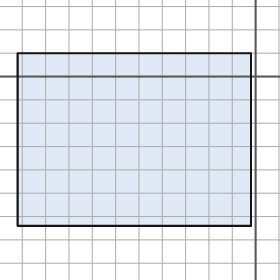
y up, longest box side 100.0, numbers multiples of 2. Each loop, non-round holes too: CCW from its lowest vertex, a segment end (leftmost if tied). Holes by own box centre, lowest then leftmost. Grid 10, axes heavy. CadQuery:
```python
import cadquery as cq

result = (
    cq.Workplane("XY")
    .moveTo(-102.0, -64.0)
    .lineTo(-2.0, -64.0)
    .lineTo(-2.0, 10.0)
    .lineTo(-102.0, 10.0)
    .close()
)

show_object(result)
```